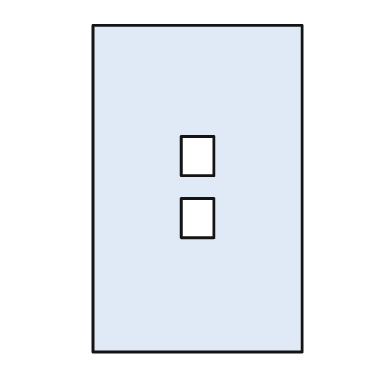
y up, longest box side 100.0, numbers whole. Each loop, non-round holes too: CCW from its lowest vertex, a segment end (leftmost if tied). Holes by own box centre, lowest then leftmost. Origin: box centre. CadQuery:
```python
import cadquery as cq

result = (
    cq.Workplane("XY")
    .moveTo(-32.0, -50.0)
    .lineTo(32.0, -50.0)
    .lineTo(32.0, 50.0)
    .lineTo(-32.0, 50.0)
    .close()
    .moveTo(-5.0, -15.0)
    .lineTo(5.0, -15.0)
    .lineTo(5.0, -3.0)
    .lineTo(-5.0, -3.0)
    .close()
    .moveTo(-5.0, 4.0)
    .lineTo(5.0, 4.0)
    .lineTo(5.0, 16.0)
    .lineTo(-5.0, 16.0)
    .close()
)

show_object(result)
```